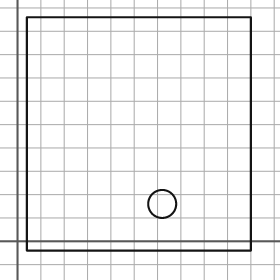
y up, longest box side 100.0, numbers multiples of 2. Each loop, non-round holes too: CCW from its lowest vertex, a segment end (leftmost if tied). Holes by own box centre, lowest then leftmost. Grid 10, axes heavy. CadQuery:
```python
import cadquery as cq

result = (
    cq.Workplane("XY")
    .moveTo(4.0, -4.0)
    .lineTo(100.0, -4.0)
    .lineTo(100.0, 96.0)
    .lineTo(4.0, 96.0)
    .close()
    .moveTo(62.0, 16.0)
    .circle(6.0)
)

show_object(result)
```